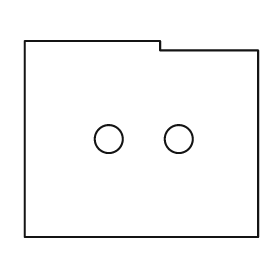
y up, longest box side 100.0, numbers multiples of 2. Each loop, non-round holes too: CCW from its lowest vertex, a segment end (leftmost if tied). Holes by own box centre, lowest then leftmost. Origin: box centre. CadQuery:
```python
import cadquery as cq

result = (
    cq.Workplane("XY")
    .moveTo(-50.0, -42.0)
    .lineTo(50.0, -42.0)
    .lineTo(50.0, 38.0)
    .lineTo(8.0, 38.0)
    .lineTo(8.0, 42.0)
    .lineTo(-50.0, 42.0)
    .close()
    .moveTo(-14.0, 0.0)
    .circle(6.0)
    .moveTo(16.0, 0.0)
    .circle(6.0)
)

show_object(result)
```